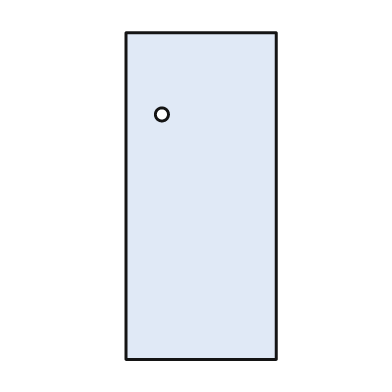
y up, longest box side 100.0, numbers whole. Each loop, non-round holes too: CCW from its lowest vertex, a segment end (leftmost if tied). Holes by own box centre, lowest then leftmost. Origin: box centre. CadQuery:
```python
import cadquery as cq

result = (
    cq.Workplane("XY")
    .moveTo(-23.0, -50.0)
    .lineTo(23.0, -50.0)
    .lineTo(23.0, 50.0)
    .lineTo(-23.0, 50.0)
    .close()
    .moveTo(-12.0, 25.0)
    .circle(2.0)
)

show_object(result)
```